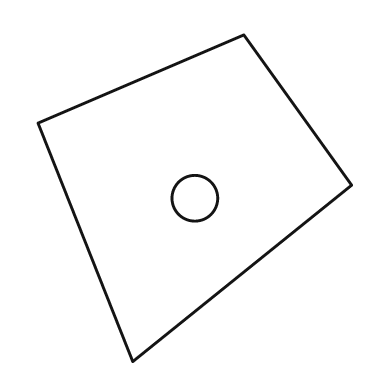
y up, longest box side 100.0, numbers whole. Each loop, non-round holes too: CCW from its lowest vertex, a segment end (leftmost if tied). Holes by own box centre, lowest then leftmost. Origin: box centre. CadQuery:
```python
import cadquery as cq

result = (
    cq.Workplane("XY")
    .moveTo(-19.0, -50.0)
    .lineTo(48.0, 4.0)
    .lineTo(15.0, 50.0)
    .lineTo(-48.0, 23.0)
    .close()
    .moveTo(0.0, 0.0)
    .circle(7.0)
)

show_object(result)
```